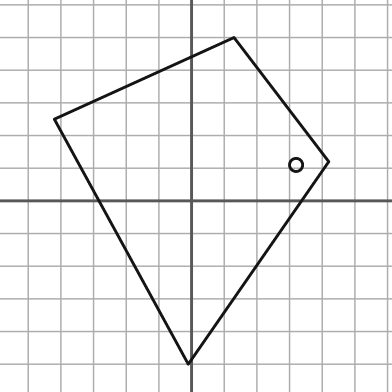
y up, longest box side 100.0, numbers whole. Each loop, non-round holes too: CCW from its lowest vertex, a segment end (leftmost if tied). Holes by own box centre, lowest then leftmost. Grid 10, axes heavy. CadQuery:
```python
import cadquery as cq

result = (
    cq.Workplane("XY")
    .moveTo(-1.0, -50.0)
    .lineTo(42.0, 12.0)
    .lineTo(13.0, 50.0)
    .lineTo(-42.0, 25.0)
    .close()
    .moveTo(32.0, 11.0)
    .circle(2.0)
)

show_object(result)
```